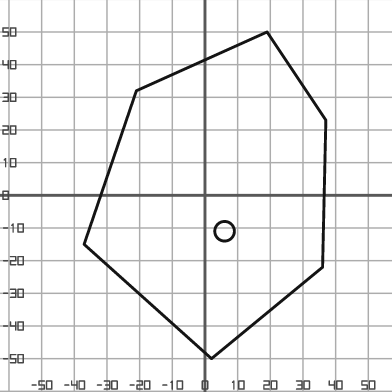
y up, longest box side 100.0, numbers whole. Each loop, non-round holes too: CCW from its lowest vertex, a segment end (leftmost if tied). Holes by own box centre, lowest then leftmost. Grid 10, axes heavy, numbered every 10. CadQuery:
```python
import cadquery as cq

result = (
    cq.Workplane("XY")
    .moveTo(2.0, -50.0)
    .lineTo(36.0, -22.0)
    .lineTo(37.0, 23.0)
    .lineTo(19.0, 50.0)
    .lineTo(-21.0, 32.0)
    .lineTo(-37.0, -15.0)
    .close()
    .moveTo(6.0, -11.0)
    .circle(3.0)
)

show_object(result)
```